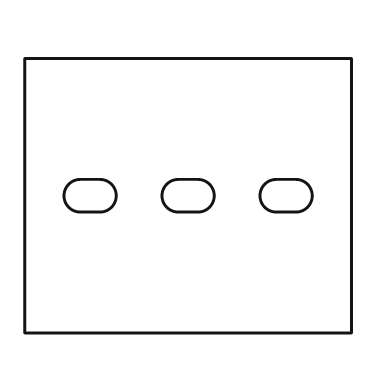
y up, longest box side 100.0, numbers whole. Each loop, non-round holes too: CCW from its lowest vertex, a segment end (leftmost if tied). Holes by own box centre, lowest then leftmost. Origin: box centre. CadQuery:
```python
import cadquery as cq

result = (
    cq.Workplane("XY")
    .moveTo(-50.0, -42.0)
    .lineTo(50.0, -42.0)
    .lineTo(50.0, 42.0)
    .lineTo(-50.0, 42.0)
    .close()
    .moveTo(-33.0, -5.0)
    .lineTo(-27.0, -5.0)
    .threePointArc((-22.0, 0.0), (-27.0, 5.0))
    .lineTo(-33.0, 5.0)
    .threePointArc((-38.0, 0.0), (-33.0, -5.0))
    .close()
    .moveTo(-3.0, -5.0)
    .lineTo(3.0, -5.0)
    .threePointArc((8.0, 0.0), (3.0, 5.0))
    .lineTo(-3.0, 5.0)
    .threePointArc((-8.0, 0.0), (-3.0, -5.0))
    .close()
    .moveTo(27.0, -5.0)
    .lineTo(33.0, -5.0)
    .threePointArc((38.0, 0.0), (33.0, 5.0))
    .lineTo(27.0, 5.0)
    .threePointArc((22.0, 0.0), (27.0, -5.0))
    .close()
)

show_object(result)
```